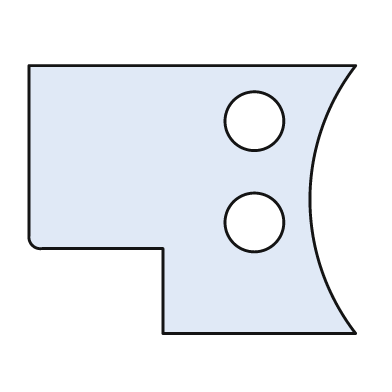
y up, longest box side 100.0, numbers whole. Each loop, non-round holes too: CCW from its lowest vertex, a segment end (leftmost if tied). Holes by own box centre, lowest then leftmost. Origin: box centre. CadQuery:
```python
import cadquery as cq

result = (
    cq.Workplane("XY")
    .moveTo(-9.0, -41.0)
    .lineTo(50.0, -41.0)
    .threePointArc((36.0, 0.0), (50.0, 41.0))
    .lineTo(-50.0, 41.0)
    .lineTo(-50.0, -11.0)
    .threePointArc((-49.0, -14.0), (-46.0, -15.0))
    .lineTo(-9.0, -15.0)
    .close()
    .moveTo(19.0, -7.0)
    .circle(9.0)
    .moveTo(19.0, 24.0)
    .circle(9.0)
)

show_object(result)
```